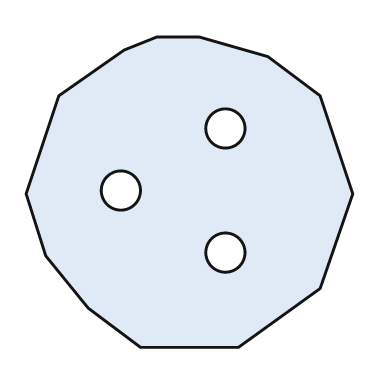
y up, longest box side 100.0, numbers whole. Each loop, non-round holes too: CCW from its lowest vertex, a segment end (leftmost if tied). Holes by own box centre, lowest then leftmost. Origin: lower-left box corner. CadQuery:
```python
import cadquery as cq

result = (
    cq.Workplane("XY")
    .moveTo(35.0, 0.0)
    .lineTo(65.0, 0.0)
    .lineTo(90.0, 18.0)
    .lineTo(100.0, 47.0)
    .lineTo(90.0, 77.0)
    .lineTo(74.0, 89.0)
    .lineTo(53.0, 95.0)
    .lineTo(40.0, 95.0)
    .lineTo(30.0, 91.0)
    .lineTo(10.0, 77.0)
    .lineTo(0.0, 47.0)
    .lineTo(6.0, 28.0)
    .lineTo(19.0, 12.0)
    .close()
    .moveTo(61.0, 29.0)
    .circle(6.0)
    .moveTo(29.0, 48.0)
    .circle(6.0)
    .moveTo(61.0, 67.0)
    .circle(6.0)
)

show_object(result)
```